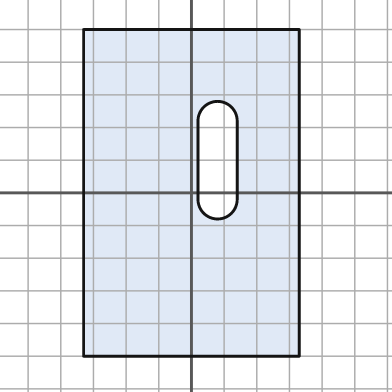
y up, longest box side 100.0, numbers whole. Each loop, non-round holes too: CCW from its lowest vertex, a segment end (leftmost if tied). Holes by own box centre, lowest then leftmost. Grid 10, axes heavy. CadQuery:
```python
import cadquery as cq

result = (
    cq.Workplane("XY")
    .moveTo(-33.0, -50.0)
    .lineTo(33.0, -50.0)
    .lineTo(33.0, 50.0)
    .lineTo(-33.0, 50.0)
    .close()
    .moveTo(2.0, -2.0)
    .threePointArc((8.0, -8.0), (14.0, -2.0))
    .lineTo(14.0, 22.0)
    .threePointArc((8.0, 28.0), (2.0, 22.0))
    .close()
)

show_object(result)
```